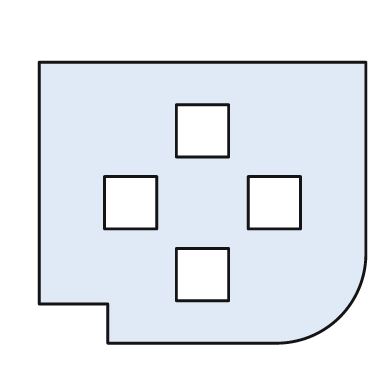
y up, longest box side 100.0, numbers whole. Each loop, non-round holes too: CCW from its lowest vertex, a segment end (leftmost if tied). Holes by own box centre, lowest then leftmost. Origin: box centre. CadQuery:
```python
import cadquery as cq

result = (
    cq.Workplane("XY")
    .moveTo(-29.0, -43.0)
    .lineTo(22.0, -43.0)
    .threePointArc((42.0, -35.0), (50.0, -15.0))
    .lineTo(50.0, 43.0)
    .lineTo(-50.0, 43.0)
    .lineTo(-50.0, -31.0)
    .lineTo(-29.0, -31.0)
    .close()
    .moveTo(-8.0, -30.0)
    .lineTo(8.0, -30.0)
    .lineTo(8.0, -14.0)
    .lineTo(-8.0, -14.0)
    .close()
    .moveTo(-30.0, -8.0)
    .lineTo(-14.0, -8.0)
    .lineTo(-14.0, 8.0)
    .lineTo(-30.0, 8.0)
    .close()
    .moveTo(14.0, -8.0)
    .lineTo(30.0, -8.0)
    .lineTo(30.0, 8.0)
    .lineTo(14.0, 8.0)
    .close()
    .moveTo(-8.0, 14.0)
    .lineTo(8.0, 14.0)
    .lineTo(8.0, 30.0)
    .lineTo(-8.0, 30.0)
    .close()
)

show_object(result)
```